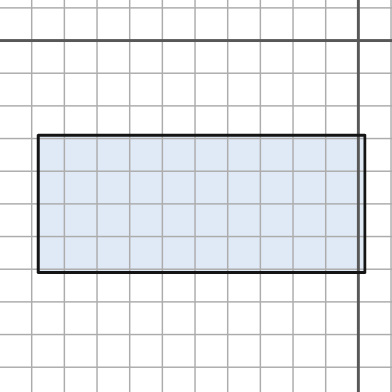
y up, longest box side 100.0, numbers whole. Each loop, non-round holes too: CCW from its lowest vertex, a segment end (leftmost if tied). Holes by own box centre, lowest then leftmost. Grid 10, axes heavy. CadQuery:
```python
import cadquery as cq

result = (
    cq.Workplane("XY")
    .moveTo(-98.0, -71.0)
    .lineTo(2.0, -71.0)
    .lineTo(2.0, -29.0)
    .lineTo(-98.0, -29.0)
    .close()
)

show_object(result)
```